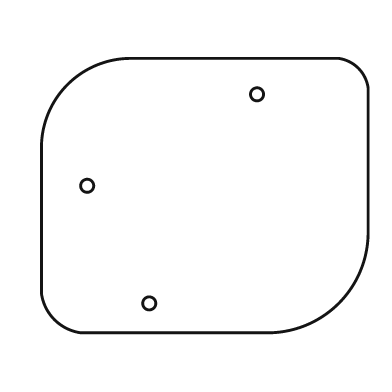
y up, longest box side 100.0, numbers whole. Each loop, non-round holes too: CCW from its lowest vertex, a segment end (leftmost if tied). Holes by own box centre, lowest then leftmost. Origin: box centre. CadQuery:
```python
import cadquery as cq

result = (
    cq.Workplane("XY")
    .moveTo(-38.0, -42.0)
    .lineTo(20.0, -42.0)
    .threePointArc((41.0, -33.0), (50.0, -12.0))
    .lineTo(50.0, 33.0)
    .threePointArc((47.0, 39.0), (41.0, 42.0))
    .lineTo(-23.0, 42.0)
    .threePointArc((-42.0, 34.0), (-50.0, 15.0))
    .lineTo(-50.0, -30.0)
    .threePointArc((-46.0, -38.0), (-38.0, -42.0))
    .close()
    .moveTo(-17.0, -33.0)
    .circle(2.0)
    .moveTo(-36.0, 3.0)
    .circle(2.0)
    .moveTo(16.0, 31.0)
    .circle(2.0)
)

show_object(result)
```